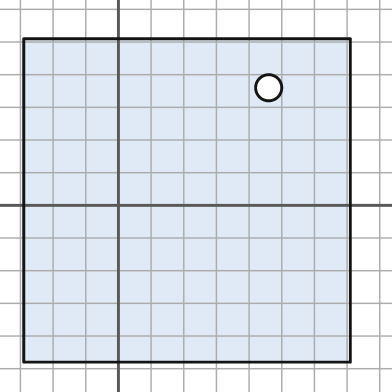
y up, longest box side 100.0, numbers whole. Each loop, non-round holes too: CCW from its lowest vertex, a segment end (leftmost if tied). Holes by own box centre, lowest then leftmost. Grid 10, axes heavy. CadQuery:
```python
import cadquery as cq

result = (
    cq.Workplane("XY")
    .moveTo(-29.0, -48.0)
    .lineTo(71.0, -48.0)
    .lineTo(71.0, 51.0)
    .lineTo(-29.0, 51.0)
    .close()
    .moveTo(46.0, 36.0)
    .circle(4.0)
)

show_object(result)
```